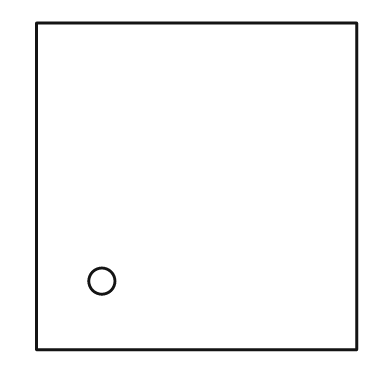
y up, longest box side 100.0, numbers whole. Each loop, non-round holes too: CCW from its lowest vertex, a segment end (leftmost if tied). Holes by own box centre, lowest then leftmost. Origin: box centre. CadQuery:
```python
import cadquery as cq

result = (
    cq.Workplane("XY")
    .moveTo(-49.0, -50.0)
    .lineTo(49.0, -50.0)
    .lineTo(49.0, 50.0)
    .lineTo(-49.0, 50.0)
    .close()
    .moveTo(-29.0, -29.0)
    .circle(4.0)
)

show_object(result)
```